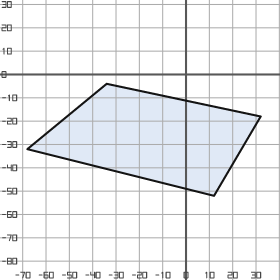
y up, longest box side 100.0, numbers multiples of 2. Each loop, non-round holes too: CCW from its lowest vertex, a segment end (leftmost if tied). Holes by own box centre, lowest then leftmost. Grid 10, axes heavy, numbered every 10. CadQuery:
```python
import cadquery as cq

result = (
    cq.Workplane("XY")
    .moveTo(12.0, -52.0)
    .lineTo(32.0, -18.0)
    .lineTo(-34.0, -4.0)
    .lineTo(-68.0, -32.0)
    .close()
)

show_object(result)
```